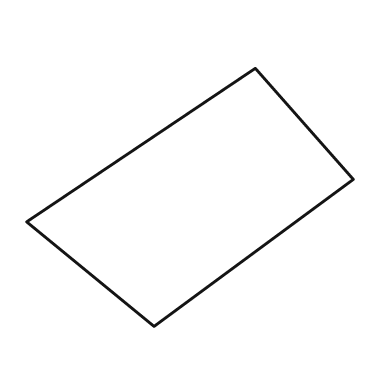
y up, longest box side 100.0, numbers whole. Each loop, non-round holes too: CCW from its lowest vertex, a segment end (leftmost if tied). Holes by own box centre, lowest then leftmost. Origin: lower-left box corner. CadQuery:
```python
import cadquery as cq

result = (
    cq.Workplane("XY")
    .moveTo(39.0, 0.0)
    .lineTo(100.0, 45.0)
    .lineTo(70.0, 79.0)
    .lineTo(0.0, 32.0)
    .close()
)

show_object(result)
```